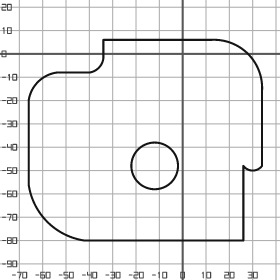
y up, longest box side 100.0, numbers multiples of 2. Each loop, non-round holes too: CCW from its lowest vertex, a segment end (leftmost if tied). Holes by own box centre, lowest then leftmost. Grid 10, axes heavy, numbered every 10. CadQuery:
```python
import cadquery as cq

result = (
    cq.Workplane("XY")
    .moveTo(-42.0, -80.0)
    .lineTo(26.0, -80.0)
    .lineTo(26.0, -48.0)
    .threePointArc((30.0, -50.0), (34.0, -48.0))
    .lineTo(34.0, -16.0)
    .threePointArc((28.0, 0.0), (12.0, 6.0))
    .lineTo(-34.0, 6.0)
    .lineTo(-34.0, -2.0)
    .threePointArc((-36.0, -6.0), (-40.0, -8.0))
    .lineTo(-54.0, -8.0)
    .threePointArc((-62.0, -12.0), (-66.0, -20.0))
    .lineTo(-66.0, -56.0)
    .threePointArc((-58.0, -72.0), (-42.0, -80.0))
    .close()
    .moveTo(-12.0, -48.0)
    .circle(10.0)
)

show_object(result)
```